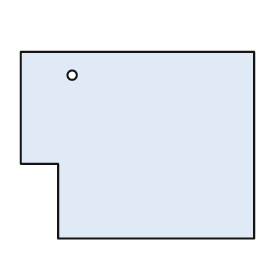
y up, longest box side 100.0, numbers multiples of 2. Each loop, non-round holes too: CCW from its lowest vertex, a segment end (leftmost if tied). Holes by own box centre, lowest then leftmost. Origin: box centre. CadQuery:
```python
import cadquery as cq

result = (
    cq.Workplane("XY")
    .moveTo(-34.0, -40.0)
    .lineTo(50.0, -40.0)
    .lineTo(50.0, 40.0)
    .lineTo(-50.0, 40.0)
    .lineTo(-50.0, -8.0)
    .lineTo(-34.0, -8.0)
    .close()
    .moveTo(-28.0, 30.0)
    .circle(2.0)
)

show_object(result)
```